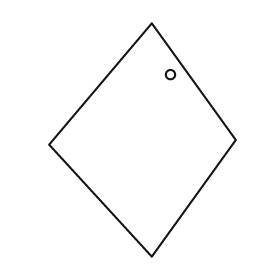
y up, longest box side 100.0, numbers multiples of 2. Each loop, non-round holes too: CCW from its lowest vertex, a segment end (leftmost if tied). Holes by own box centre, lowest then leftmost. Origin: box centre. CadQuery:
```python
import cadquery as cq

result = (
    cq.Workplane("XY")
    .moveTo(4.0, -50.0)
    .lineTo(40.0, 0.0)
    .lineTo(4.0, 50.0)
    .lineTo(-40.0, -2.0)
    .close()
    .moveTo(12.0, 28.0)
    .circle(2.0)
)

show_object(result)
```